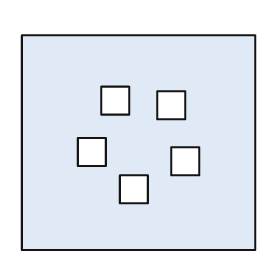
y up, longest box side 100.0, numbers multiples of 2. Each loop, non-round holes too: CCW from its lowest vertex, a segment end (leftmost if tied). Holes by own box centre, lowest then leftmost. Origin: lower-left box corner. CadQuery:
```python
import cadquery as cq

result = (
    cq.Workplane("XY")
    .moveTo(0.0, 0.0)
    .lineTo(100.0, 0.0)
    .lineTo(100.0, 92.0)
    .lineTo(0.0, 92.0)
    .close()
    .moveTo(42.0, 20.0)
    .lineTo(54.0, 20.0)
    .lineTo(54.0, 32.0)
    .lineTo(42.0, 32.0)
    .close()
    .moveTo(64.0, 32.0)
    .lineTo(76.0, 32.0)
    .lineTo(76.0, 44.0)
    .lineTo(64.0, 44.0)
    .close()
    .moveTo(24.0, 36.0)
    .lineTo(36.0, 36.0)
    .lineTo(36.0, 48.0)
    .lineTo(24.0, 48.0)
    .close()
    .moveTo(58.0, 56.0)
    .lineTo(70.0, 56.0)
    .lineTo(70.0, 68.0)
    .lineTo(58.0, 68.0)
    .close()
    .moveTo(34.0, 58.0)
    .lineTo(46.0, 58.0)
    .lineTo(46.0, 70.0)
    .lineTo(34.0, 70.0)
    .close()
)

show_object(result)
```